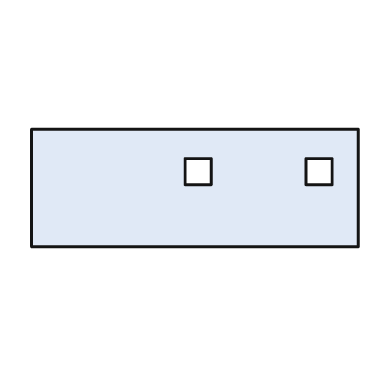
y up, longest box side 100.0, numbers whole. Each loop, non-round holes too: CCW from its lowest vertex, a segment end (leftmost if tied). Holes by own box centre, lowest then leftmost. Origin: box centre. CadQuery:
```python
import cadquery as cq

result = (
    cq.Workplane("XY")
    .moveTo(-50.0, -18.0)
    .lineTo(50.0, -18.0)
    .lineTo(50.0, 18.0)
    .lineTo(-50.0, 18.0)
    .close()
    .moveTo(-3.0, 1.0)
    .lineTo(5.0, 1.0)
    .lineTo(5.0, 9.0)
    .lineTo(-3.0, 9.0)
    .close()
    .moveTo(34.0, 1.0)
    .lineTo(42.0, 1.0)
    .lineTo(42.0, 9.0)
    .lineTo(34.0, 9.0)
    .close()
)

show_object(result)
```